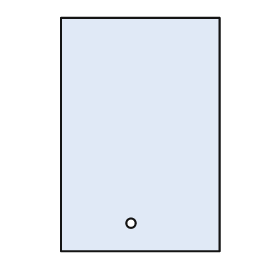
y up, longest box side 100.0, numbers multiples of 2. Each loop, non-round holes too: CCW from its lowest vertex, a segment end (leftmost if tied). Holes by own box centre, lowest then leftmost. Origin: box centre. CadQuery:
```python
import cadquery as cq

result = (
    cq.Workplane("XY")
    .moveTo(-34.0, -50.0)
    .lineTo(34.0, -50.0)
    .lineTo(34.0, 50.0)
    .lineTo(-34.0, 50.0)
    .close()
    .moveTo(-4.0, -38.0)
    .circle(2.0)
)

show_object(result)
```